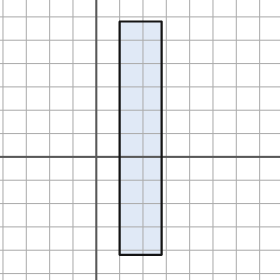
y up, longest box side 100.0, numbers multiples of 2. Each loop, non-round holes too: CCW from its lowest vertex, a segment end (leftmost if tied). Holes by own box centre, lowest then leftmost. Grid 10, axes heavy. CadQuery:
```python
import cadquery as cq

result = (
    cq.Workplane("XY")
    .moveTo(10.0, -42.0)
    .lineTo(28.0, -42.0)
    .lineTo(28.0, 58.0)
    .lineTo(10.0, 58.0)
    .close()
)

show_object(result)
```